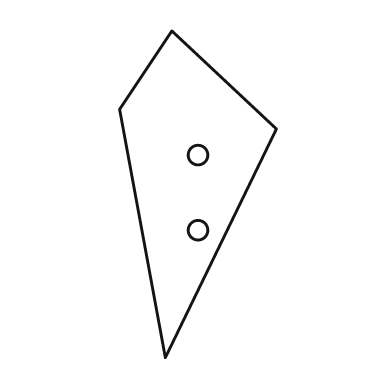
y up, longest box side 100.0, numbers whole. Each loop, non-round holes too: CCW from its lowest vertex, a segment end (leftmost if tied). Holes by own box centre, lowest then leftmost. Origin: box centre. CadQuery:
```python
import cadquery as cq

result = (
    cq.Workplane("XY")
    .moveTo(-10.0, -50.0)
    .lineTo(24.0, 20.0)
    .lineTo(-8.0, 50.0)
    .lineTo(-24.0, 26.0)
    .close()
    .moveTo(0.0, -11.0)
    .circle(3.0)
    .moveTo(0.0, 12.0)
    .circle(3.0)
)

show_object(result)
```